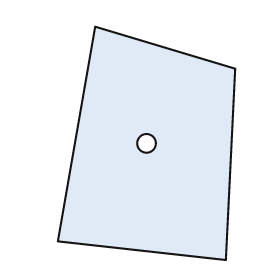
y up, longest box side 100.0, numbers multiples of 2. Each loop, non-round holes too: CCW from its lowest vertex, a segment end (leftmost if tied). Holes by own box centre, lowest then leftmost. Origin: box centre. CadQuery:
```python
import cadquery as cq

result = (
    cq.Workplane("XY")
    .moveTo(34.0, -50.0)
    .lineTo(38.0, 32.0)
    .lineTo(-22.0, 50.0)
    .lineTo(-38.0, -42.0)
    .close()
    .moveTo(0.0, 0.0)
    .circle(4.0)
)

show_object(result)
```